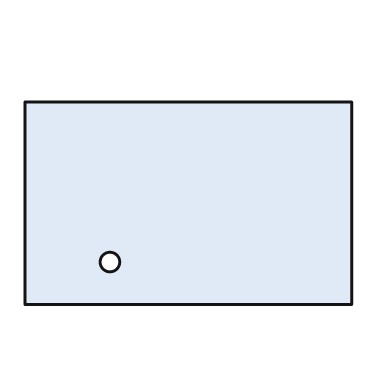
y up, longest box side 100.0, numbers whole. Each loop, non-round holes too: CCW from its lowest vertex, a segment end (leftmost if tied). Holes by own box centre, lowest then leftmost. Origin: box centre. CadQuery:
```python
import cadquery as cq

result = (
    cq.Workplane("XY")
    .moveTo(-50.0, -31.0)
    .lineTo(50.0, -31.0)
    .lineTo(50.0, 31.0)
    .lineTo(-50.0, 31.0)
    .close()
    .moveTo(-24.0, -18.0)
    .circle(3.0)
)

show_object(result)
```